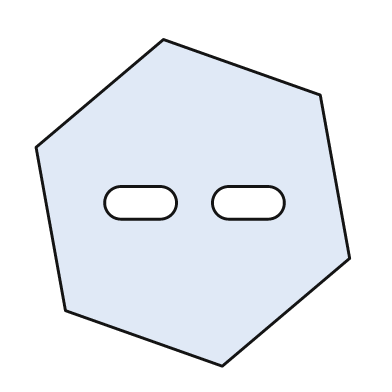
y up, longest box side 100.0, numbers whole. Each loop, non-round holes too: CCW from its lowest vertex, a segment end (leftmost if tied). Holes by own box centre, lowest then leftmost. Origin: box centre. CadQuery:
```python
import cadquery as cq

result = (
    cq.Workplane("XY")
    .moveTo(9.0, -50.0)
    .lineTo(48.0, -17.0)
    .lineTo(39.0, 33.0)
    .lineTo(-9.0, 50.0)
    .lineTo(-48.0, 17.0)
    .lineTo(-39.0, -33.0)
    .close()
    .moveTo(-22.0, -5.0)
    .lineTo(-10.0, -5.0)
    .threePointArc((-5.0, 0.0), (-10.0, 5.0))
    .lineTo(-22.0, 5.0)
    .threePointArc((-27.0, 0.0), (-22.0, -5.0))
    .close()
    .moveTo(11.0, -5.0)
    .lineTo(23.0, -5.0)
    .threePointArc((28.0, 0.0), (23.0, 5.0))
    .lineTo(11.0, 5.0)
    .threePointArc((6.0, 0.0), (11.0, -5.0))
    .close()
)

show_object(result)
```